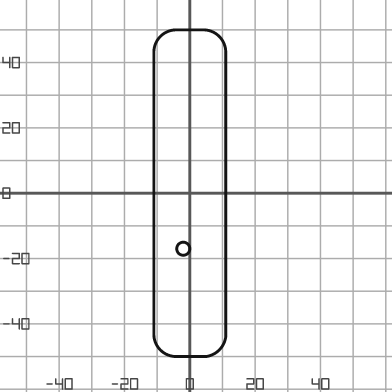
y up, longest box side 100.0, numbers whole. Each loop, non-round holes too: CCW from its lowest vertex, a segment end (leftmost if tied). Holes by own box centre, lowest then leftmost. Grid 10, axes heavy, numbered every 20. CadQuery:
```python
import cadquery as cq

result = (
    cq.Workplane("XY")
    .moveTo(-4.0, -50.0)
    .lineTo(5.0, -50.0)
    .threePointArc((9.0, -48.0), (11.0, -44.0))
    .lineTo(11.0, 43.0)
    .threePointArc((9.0, 48.0), (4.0, 50.0))
    .lineTo(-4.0, 50.0)
    .threePointArc((-9.0, 48.0), (-11.0, 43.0))
    .lineTo(-11.0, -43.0)
    .threePointArc((-9.0, -48.0), (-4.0, -50.0))
    .close()
    .moveTo(-2.0, -17.0)
    .circle(2.0)
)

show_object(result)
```